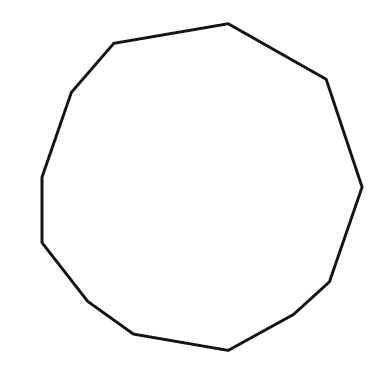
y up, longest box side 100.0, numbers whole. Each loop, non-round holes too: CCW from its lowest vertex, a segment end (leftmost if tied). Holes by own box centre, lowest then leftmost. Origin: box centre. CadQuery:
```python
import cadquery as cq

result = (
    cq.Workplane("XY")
    .moveTo(8.0, -50.0)
    .lineTo(28.0, -39.0)
    .lineTo(39.0, -29.0)
    .lineTo(49.0, 0.0)
    .lineTo(38.0, 33.0)
    .lineTo(8.0, 50.0)
    .lineTo(-27.0, 44.0)
    .lineTo(-40.0, 29.0)
    .lineTo(-49.0, 3.0)
    .lineTo(-49.0, -17.0)
    .lineTo(-35.0, -35.0)
    .lineTo(-21.0, -45.0)
    .close()
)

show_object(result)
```